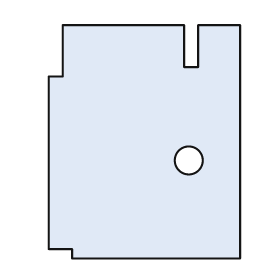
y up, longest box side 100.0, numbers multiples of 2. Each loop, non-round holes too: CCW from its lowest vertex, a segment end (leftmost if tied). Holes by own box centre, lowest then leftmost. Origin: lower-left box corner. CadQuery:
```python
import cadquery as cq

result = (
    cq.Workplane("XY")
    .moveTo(10.0, 0.0)
    .lineTo(82.0, 0.0)
    .lineTo(82.0, 100.0)
    .lineTo(64.0, 100.0)
    .lineTo(64.0, 82.0)
    .lineTo(58.0, 82.0)
    .lineTo(58.0, 100.0)
    .lineTo(6.0, 100.0)
    .lineTo(6.0, 78.0)
    .lineTo(0.0, 78.0)
    .lineTo(0.0, 4.0)
    .lineTo(10.0, 4.0)
    .close()
    .moveTo(60.0, 42.0)
    .circle(6.0)
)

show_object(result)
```